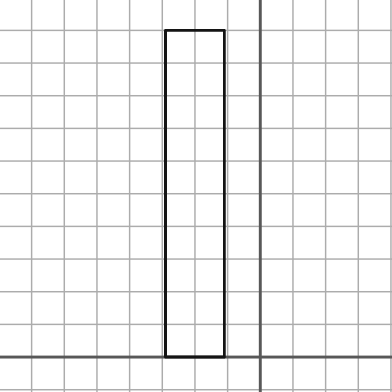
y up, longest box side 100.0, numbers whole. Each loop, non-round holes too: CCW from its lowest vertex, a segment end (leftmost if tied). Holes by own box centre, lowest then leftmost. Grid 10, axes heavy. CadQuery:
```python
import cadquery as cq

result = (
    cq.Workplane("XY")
    .moveTo(-29.0, 0.0)
    .lineTo(-11.0, 0.0)
    .lineTo(-11.0, 100.0)
    .lineTo(-29.0, 100.0)
    .close()
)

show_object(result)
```